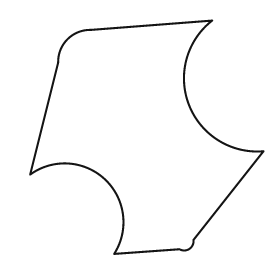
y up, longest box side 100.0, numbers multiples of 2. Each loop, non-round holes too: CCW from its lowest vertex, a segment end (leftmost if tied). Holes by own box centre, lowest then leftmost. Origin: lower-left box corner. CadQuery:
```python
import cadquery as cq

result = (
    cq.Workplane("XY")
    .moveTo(36.0, 0.0)
    .lineTo(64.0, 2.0)
    .threePointArc((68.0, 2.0), (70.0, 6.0))
    .lineTo(100.0, 44.0)
    .threePointArc((68.0, 64.0), (78.0, 100.0))
    .lineTo(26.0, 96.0)
    .threePointArc((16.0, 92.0), (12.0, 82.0))
    .lineTo(0.0, 34.0)
    .threePointArc((32.0, 32.0), (36.0, 0.0))
    .close()
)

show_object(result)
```